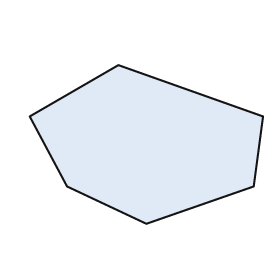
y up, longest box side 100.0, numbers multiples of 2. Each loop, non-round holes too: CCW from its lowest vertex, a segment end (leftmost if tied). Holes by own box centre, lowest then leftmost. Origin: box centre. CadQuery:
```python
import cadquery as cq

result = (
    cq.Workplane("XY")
    .moveTo(0.0, -34.0)
    .lineTo(46.0, -18.0)
    .lineTo(50.0, 12.0)
    .lineTo(-12.0, 34.0)
    .lineTo(-50.0, 12.0)
    .lineTo(-34.0, -18.0)
    .close()
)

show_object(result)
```